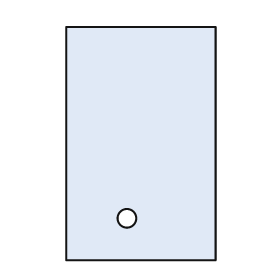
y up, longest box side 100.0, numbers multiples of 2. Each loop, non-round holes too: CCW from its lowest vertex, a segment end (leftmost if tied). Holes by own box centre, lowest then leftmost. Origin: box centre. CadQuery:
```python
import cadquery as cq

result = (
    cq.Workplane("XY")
    .moveTo(-32.0, -50.0)
    .lineTo(32.0, -50.0)
    .lineTo(32.0, 50.0)
    .lineTo(-32.0, 50.0)
    .close()
    .moveTo(-6.0, -32.0)
    .circle(4.0)
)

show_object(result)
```